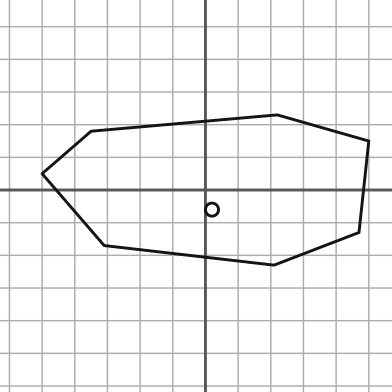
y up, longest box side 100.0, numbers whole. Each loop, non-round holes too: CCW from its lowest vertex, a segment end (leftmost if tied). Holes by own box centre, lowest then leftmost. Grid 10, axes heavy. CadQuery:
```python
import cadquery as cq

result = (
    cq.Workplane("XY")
    .moveTo(21.0, -23.0)
    .lineTo(47.0, -13.0)
    .lineTo(50.0, 15.0)
    .lineTo(22.0, 23.0)
    .lineTo(-35.0, 18.0)
    .lineTo(-50.0, 5.0)
    .lineTo(-31.0, -17.0)
    .close()
    .moveTo(2.0, -6.0)
    .circle(2.0)
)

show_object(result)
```